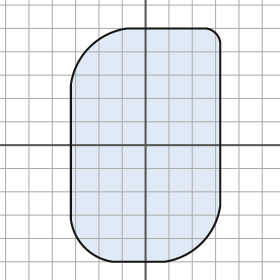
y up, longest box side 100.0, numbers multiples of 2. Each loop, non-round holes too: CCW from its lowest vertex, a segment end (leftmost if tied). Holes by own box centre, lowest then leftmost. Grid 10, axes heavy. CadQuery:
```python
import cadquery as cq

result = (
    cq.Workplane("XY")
    .moveTo(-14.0, -50.0)
    .lineTo(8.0, -50.0)
    .threePointArc((24.0, -42.0), (32.0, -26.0))
    .lineTo(32.0, 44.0)
    .threePointArc((30.0, 48.0), (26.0, 50.0))
    .lineTo(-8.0, 50.0)
    .threePointArc((-24.0, 42.0), (-32.0, 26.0))
    .lineTo(-32.0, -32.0)
    .threePointArc((-26.0, -44.0), (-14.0, -50.0))
    .close()
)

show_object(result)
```